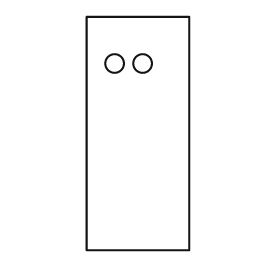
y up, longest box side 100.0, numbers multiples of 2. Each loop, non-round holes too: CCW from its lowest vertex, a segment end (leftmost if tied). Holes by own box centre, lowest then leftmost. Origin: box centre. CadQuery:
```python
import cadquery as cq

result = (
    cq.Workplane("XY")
    .moveTo(-22.0, -50.0)
    .lineTo(22.0, -50.0)
    .lineTo(22.0, 50.0)
    .lineTo(-22.0, 50.0)
    .close()
    .moveTo(-10.0, 30.0)
    .circle(4.0)
    .moveTo(2.0, 30.0)
    .circle(4.0)
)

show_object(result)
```